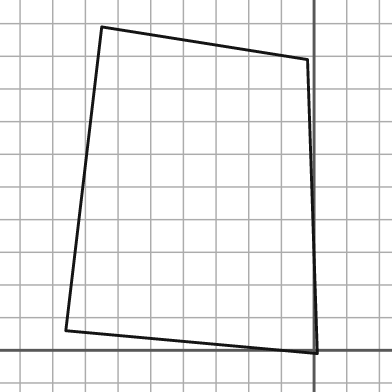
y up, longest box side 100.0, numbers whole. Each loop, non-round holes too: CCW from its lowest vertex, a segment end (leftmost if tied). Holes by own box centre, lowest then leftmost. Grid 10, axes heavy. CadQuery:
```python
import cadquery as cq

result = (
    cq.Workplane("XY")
    .moveTo(1.0, -1.0)
    .lineTo(-2.0, 89.0)
    .lineTo(-65.0, 99.0)
    .lineTo(-76.0, 6.0)
    .close()
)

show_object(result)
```